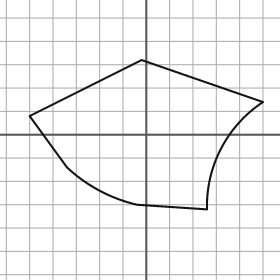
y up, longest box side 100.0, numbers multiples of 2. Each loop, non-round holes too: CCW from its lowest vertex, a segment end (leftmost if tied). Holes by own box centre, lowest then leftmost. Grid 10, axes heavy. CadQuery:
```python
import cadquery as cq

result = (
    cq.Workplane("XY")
    .moveTo(26.0, -32.0)
    .threePointArc((32.0, -6.0), (50.0, 14.0))
    .lineTo(-2.0, 32.0)
    .lineTo(-50.0, 8.0)
    .lineTo(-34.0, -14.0)
    .threePointArc((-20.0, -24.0), (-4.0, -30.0))
    .close()
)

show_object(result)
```